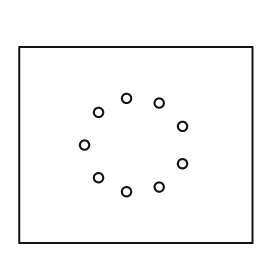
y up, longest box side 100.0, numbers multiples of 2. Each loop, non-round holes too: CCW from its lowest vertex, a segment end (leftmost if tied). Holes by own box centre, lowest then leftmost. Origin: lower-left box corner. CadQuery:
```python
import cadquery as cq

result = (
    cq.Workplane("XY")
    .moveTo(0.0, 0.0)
    .lineTo(100.0, 0.0)
    .lineTo(100.0, 84.0)
    .lineTo(0.0, 84.0)
    .close()
    .moveTo(46.0, 22.0)
    .circle(2.0)
    .moveTo(60.0, 24.0)
    .circle(2.0)
    .moveTo(34.0, 28.0)
    .circle(2.0)
    .moveTo(70.0, 34.0)
    .circle(2.0)
    .moveTo(28.0, 42.0)
    .circle(2.0)
    .moveTo(70.0, 50.0)
    .circle(2.0)
    .moveTo(34.0, 56.0)
    .circle(2.0)
    .moveTo(60.0, 60.0)
    .circle(2.0)
    .moveTo(46.0, 62.0)
    .circle(2.0)
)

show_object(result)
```